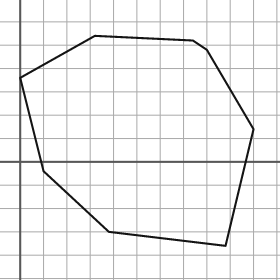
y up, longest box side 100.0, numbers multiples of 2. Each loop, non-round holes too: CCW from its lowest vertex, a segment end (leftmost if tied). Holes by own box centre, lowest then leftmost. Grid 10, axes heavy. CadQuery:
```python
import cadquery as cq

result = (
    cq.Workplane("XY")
    .moveTo(88.0, -36.0)
    .lineTo(100.0, 14.0)
    .lineTo(80.0, 48.0)
    .lineTo(74.0, 52.0)
    .lineTo(32.0, 54.0)
    .lineTo(0.0, 36.0)
    .lineTo(10.0, -4.0)
    .lineTo(38.0, -30.0)
    .close()
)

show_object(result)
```